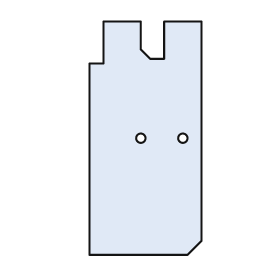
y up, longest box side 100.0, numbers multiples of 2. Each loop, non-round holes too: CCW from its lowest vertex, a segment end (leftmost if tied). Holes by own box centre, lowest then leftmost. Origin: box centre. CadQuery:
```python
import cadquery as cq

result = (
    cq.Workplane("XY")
    .moveTo(-24.0, -50.0)
    .lineTo(18.0, -50.0)
    .lineTo(24.0, -44.0)
    .lineTo(24.0, 50.0)
    .lineTo(8.0, 50.0)
    .lineTo(8.0, 34.0)
    .lineTo(2.0, 34.0)
    .lineTo(-2.0, 38.0)
    .lineTo(-2.0, 50.0)
    .lineTo(-18.0, 50.0)
    .lineTo(-18.0, 32.0)
    .lineTo(-24.0, 32.0)
    .close()
    .moveTo(-2.0, 0.0)
    .circle(2.0)
    .moveTo(16.0, 0.0)
    .circle(2.0)
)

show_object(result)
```